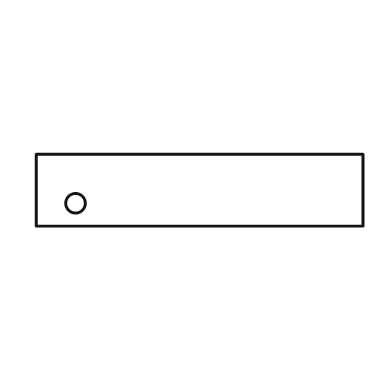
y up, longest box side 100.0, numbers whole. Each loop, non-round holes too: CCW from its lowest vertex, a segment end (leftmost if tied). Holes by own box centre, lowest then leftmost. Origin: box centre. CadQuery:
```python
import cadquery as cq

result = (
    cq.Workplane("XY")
    .moveTo(-50.0, -11.0)
    .lineTo(50.0, -11.0)
    .lineTo(50.0, 11.0)
    .lineTo(-50.0, 11.0)
    .close()
    .moveTo(-38.0, -4.0)
    .circle(3.0)
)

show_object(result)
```